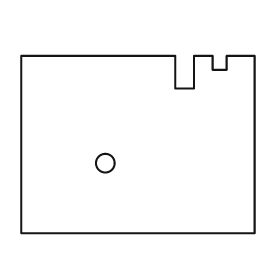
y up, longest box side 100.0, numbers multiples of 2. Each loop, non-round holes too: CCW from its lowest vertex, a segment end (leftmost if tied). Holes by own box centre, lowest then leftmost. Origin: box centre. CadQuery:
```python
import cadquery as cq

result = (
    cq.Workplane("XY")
    .moveTo(-50.0, -38.0)
    .lineTo(50.0, -38.0)
    .lineTo(50.0, 38.0)
    .lineTo(38.0, 38.0)
    .lineTo(38.0, 32.0)
    .lineTo(32.0, 32.0)
    .lineTo(32.0, 38.0)
    .lineTo(24.0, 38.0)
    .lineTo(24.0, 24.0)
    .lineTo(16.0, 24.0)
    .lineTo(16.0, 38.0)
    .lineTo(-50.0, 38.0)
    .close()
    .moveTo(-14.0, -8.0)
    .circle(4.0)
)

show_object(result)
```